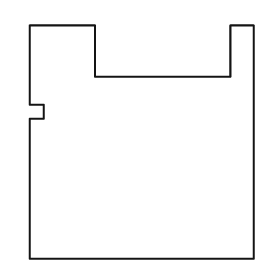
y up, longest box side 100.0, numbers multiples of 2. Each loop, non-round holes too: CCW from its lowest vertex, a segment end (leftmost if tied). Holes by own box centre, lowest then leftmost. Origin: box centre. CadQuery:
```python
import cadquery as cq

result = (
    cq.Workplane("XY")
    .moveTo(-48.0, -50.0)
    .lineTo(48.0, -50.0)
    .lineTo(48.0, 50.0)
    .lineTo(38.0, 50.0)
    .lineTo(38.0, 28.0)
    .lineTo(-20.0, 28.0)
    .lineTo(-20.0, 50.0)
    .lineTo(-48.0, 50.0)
    .lineTo(-48.0, 16.0)
    .lineTo(-42.0, 16.0)
    .lineTo(-42.0, 10.0)
    .lineTo(-48.0, 10.0)
    .close()
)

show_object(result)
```